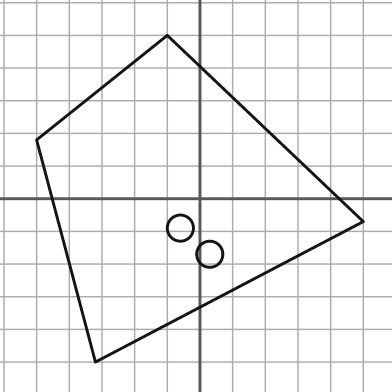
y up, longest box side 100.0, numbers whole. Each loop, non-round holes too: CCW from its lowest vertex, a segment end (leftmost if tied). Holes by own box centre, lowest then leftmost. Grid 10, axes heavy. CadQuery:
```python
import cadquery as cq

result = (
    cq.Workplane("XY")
    .moveTo(-32.0, -50.0)
    .lineTo(50.0, -7.0)
    .lineTo(-10.0, 50.0)
    .lineTo(-50.0, 18.0)
    .close()
    .moveTo(3.0, -17.0)
    .circle(4.0)
    .moveTo(-6.0, -9.0)
    .circle(4.0)
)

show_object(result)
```